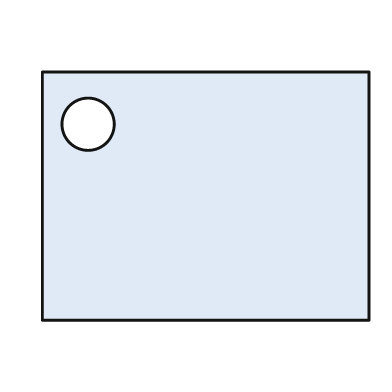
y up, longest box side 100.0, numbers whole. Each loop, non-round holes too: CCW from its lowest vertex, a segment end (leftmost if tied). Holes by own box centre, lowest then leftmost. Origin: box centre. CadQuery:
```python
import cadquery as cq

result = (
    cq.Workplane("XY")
    .moveTo(-50.0, -38.0)
    .lineTo(50.0, -38.0)
    .lineTo(50.0, 38.0)
    .lineTo(-50.0, 38.0)
    .close()
    .moveTo(-36.0, 22.0)
    .circle(8.0)
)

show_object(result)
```